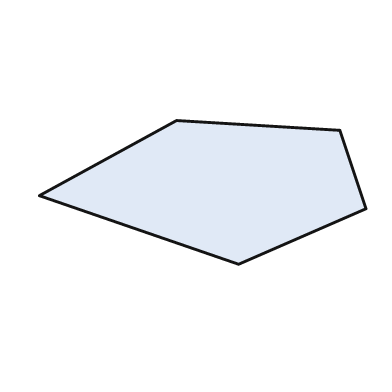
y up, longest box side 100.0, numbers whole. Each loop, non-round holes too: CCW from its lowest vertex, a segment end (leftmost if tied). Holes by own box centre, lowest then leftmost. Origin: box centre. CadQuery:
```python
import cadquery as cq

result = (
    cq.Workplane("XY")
    .moveTo(11.0, -22.0)
    .lineTo(50.0, -5.0)
    .lineTo(42.0, 19.0)
    .lineTo(-8.0, 22.0)
    .lineTo(-50.0, -1.0)
    .close()
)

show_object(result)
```